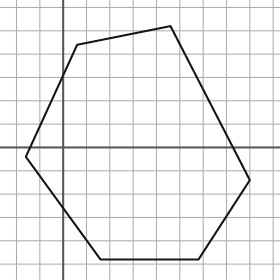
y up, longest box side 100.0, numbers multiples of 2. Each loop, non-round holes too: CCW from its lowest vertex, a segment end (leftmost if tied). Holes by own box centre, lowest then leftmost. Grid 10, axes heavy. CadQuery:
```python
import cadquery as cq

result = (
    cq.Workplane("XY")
    .moveTo(16.0, -48.0)
    .lineTo(58.0, -48.0)
    .lineTo(80.0, -14.0)
    .lineTo(46.0, 52.0)
    .lineTo(6.0, 44.0)
    .lineTo(-16.0, -4.0)
    .close()
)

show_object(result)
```